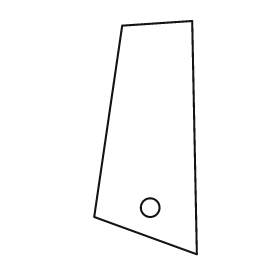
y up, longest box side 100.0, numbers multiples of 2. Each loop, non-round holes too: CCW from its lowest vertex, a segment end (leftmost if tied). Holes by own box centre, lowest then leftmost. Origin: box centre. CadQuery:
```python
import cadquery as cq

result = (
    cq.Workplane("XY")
    .moveTo(22.0, -50.0)
    .lineTo(20.0, 50.0)
    .lineTo(-10.0, 48.0)
    .lineTo(-22.0, -34.0)
    .close()
    .moveTo(2.0, -30.0)
    .circle(4.0)
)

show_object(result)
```